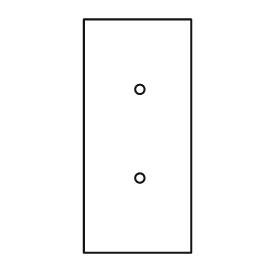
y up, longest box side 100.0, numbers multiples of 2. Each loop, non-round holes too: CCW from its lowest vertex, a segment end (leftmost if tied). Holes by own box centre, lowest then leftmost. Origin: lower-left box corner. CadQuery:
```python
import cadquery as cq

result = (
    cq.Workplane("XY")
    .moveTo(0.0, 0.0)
    .lineTo(46.0, 0.0)
    .lineTo(46.0, 100.0)
    .lineTo(0.0, 100.0)
    .close()
    .moveTo(24.0, 32.0)
    .circle(2.0)
    .moveTo(24.0, 70.0)
    .circle(2.0)
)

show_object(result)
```